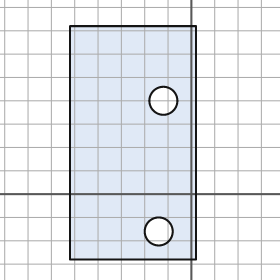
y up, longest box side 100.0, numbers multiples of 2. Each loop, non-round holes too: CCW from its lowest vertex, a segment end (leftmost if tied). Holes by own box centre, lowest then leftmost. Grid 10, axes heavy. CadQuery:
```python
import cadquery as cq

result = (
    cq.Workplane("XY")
    .moveTo(-52.0, -28.0)
    .lineTo(2.0, -28.0)
    .lineTo(2.0, 72.0)
    .lineTo(-52.0, 72.0)
    .close()
    .moveTo(-14.0, -16.0)
    .circle(6.0)
    .moveTo(-12.0, 40.0)
    .circle(6.0)
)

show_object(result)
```